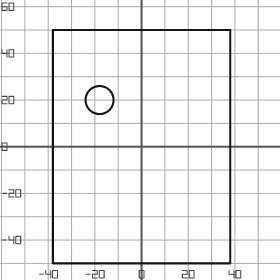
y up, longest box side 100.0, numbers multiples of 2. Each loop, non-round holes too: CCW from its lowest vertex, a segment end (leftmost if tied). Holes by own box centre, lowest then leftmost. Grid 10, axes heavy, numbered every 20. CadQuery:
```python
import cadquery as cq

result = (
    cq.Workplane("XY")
    .moveTo(-38.0, -50.0)
    .lineTo(38.0, -50.0)
    .lineTo(38.0, 50.0)
    .lineTo(-38.0, 50.0)
    .close()
    .moveTo(-18.0, 20.0)
    .circle(6.0)
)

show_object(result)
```